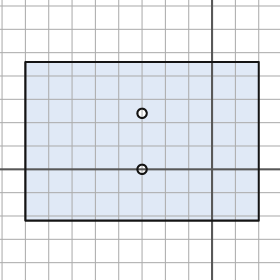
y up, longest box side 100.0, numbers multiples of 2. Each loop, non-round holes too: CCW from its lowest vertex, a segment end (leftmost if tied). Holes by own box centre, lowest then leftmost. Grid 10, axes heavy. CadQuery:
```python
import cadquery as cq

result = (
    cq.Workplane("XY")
    .moveTo(-80.0, -22.0)
    .lineTo(20.0, -22.0)
    .lineTo(20.0, 46.0)
    .lineTo(-80.0, 46.0)
    .close()
    .moveTo(-30.0, 0.0)
    .circle(2.0)
    .moveTo(-30.0, 24.0)
    .circle(2.0)
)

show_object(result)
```